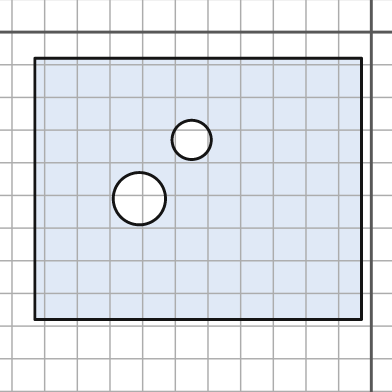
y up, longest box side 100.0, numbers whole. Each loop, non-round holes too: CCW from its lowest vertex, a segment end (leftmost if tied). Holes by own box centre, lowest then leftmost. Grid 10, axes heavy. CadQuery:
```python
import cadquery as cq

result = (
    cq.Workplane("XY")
    .moveTo(-103.0, -88.0)
    .lineTo(-3.0, -88.0)
    .lineTo(-3.0, -8.0)
    .lineTo(-103.0, -8.0)
    .close()
    .moveTo(-71.0, -51.0)
    .circle(8.0)
    .moveTo(-55.0, -33.0)
    .circle(6.0)
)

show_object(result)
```